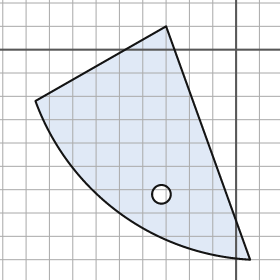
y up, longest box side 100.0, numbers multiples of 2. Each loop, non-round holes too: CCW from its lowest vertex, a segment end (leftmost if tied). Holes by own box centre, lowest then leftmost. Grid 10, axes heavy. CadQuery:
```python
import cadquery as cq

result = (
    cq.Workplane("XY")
    .moveTo(6.0, -90.0)
    .lineTo(-30.0, 10.0)
    .lineTo(-86.0, -22.0)
    .threePointArc((-50.0, -70.0), (6.0, -90.0))
    .close()
    .moveTo(-32.0, -62.0)
    .circle(4.0)
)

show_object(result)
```